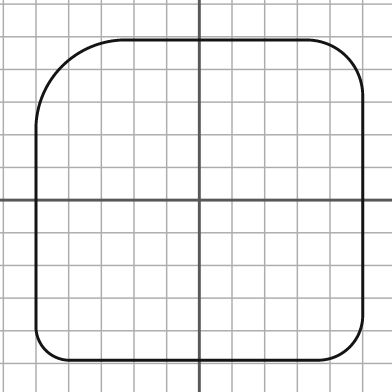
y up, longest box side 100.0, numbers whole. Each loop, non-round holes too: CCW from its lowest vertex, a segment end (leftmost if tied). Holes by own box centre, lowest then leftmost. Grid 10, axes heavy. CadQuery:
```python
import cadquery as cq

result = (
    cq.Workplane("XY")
    .moveTo(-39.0, -49.0)
    .lineTo(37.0, -49.0)
    .threePointArc((46.0, -45.0), (50.0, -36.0))
    .lineTo(50.0, 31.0)
    .threePointArc((45.0, 44.0), (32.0, 49.0))
    .lineTo(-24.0, 49.0)
    .threePointArc((-42.0, 41.0), (-50.0, 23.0))
    .lineTo(-50.0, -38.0)
    .threePointArc((-47.0, -46.0), (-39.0, -49.0))
    .close()
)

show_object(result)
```